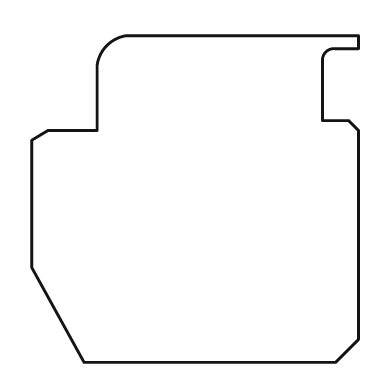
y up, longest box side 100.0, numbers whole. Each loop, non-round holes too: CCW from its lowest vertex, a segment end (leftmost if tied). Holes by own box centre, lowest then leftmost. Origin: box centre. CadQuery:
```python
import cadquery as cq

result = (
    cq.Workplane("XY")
    .moveTo(-34.0, -50.0)
    .lineTo(43.0, -50.0)
    .lineTo(50.0, -43.0)
    .lineTo(50.0, 21.0)
    .lineTo(47.0, 24.0)
    .lineTo(39.0, 24.0)
    .lineTo(39.0, 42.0)
    .threePointArc((40.0, 45.0), (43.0, 46.0))
    .lineTo(50.0, 46.0)
    .lineTo(50.0, 50.0)
    .lineTo(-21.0, 50.0)
    .threePointArc((-27.0, 47.0), (-30.0, 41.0))
    .lineTo(-30.0, 21.0)
    .lineTo(-45.0, 21.0)
    .lineTo(-50.0, 18.0)
    .lineTo(-50.0, -21.0)
    .close()
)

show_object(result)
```